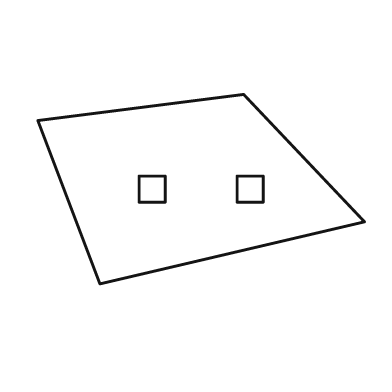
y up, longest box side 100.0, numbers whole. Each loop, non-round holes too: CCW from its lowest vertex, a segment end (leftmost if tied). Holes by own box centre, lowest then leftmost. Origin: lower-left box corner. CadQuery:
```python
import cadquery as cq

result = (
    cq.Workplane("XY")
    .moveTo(19.0, 0.0)
    .lineTo(100.0, 19.0)
    .lineTo(63.0, 58.0)
    .lineTo(0.0, 50.0)
    .close()
    .moveTo(31.0, 25.0)
    .lineTo(39.0, 25.0)
    .lineTo(39.0, 33.0)
    .lineTo(31.0, 33.0)
    .close()
    .moveTo(61.0, 25.0)
    .lineTo(69.0, 25.0)
    .lineTo(69.0, 33.0)
    .lineTo(61.0, 33.0)
    .close()
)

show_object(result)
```